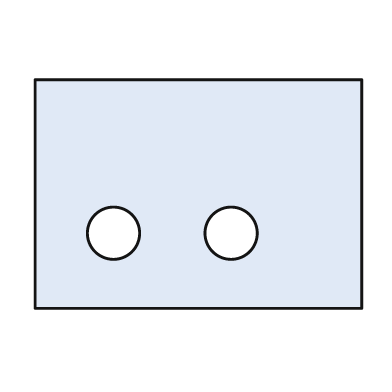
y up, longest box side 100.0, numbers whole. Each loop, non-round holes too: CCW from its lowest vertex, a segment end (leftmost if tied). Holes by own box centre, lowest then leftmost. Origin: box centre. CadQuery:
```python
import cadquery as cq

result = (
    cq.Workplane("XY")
    .moveTo(-50.0, -35.0)
    .lineTo(50.0, -35.0)
    .lineTo(50.0, 35.0)
    .lineTo(-50.0, 35.0)
    .close()
    .moveTo(-26.0, -12.0)
    .circle(8.0)
    .moveTo(10.0, -12.0)
    .circle(8.0)
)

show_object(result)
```